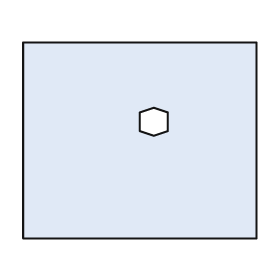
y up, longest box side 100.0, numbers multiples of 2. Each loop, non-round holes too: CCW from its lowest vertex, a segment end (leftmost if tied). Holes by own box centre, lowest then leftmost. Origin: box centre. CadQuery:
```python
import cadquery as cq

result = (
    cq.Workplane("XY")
    .moveTo(-50.0, -42.0)
    .lineTo(50.0, -42.0)
    .lineTo(50.0, 42.0)
    .lineTo(-50.0, 42.0)
    .close()
    .moveTo(6.0, 2.0)
    .lineTo(12.0, 4.0)
    .lineTo(12.0, 12.0)
    .lineTo(6.0, 14.0)
    .lineTo(0.0, 12.0)
    .lineTo(0.0, 4.0)
    .close()
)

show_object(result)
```